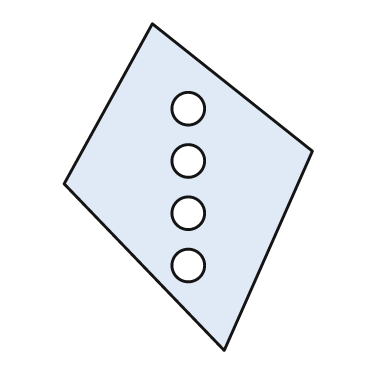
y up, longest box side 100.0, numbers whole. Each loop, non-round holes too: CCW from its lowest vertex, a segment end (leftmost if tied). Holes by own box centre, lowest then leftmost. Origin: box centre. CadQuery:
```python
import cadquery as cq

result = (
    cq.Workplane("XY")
    .moveTo(11.0, -50.0)
    .lineTo(38.0, 11.0)
    .lineTo(-11.0, 50.0)
    .lineTo(-38.0, 1.0)
    .close()
    .moveTo(0.0, -24.0)
    .circle(5.0)
    .moveTo(0.0, -8.0)
    .circle(5.0)
    .moveTo(0.0, 8.0)
    .circle(5.0)
    .moveTo(0.0, 24.0)
    .circle(5.0)
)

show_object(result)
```